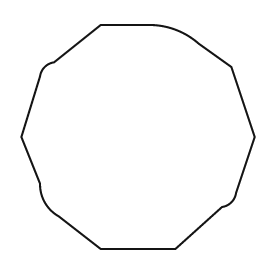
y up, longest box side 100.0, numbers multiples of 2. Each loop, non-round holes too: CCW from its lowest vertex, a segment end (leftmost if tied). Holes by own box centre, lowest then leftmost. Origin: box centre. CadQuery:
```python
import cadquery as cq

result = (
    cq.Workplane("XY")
    .moveTo(-16.0, -48.0)
    .lineTo(16.0, -48.0)
    .lineTo(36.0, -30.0)
    .threePointArc((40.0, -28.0), (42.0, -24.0))
    .lineTo(50.0, 0.0)
    .lineTo(40.0, 30.0)
    .lineTo(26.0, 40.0)
    .threePointArc((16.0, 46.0), (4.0, 48.0))
    .lineTo(-16.0, 48.0)
    .lineTo(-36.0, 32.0)
    .threePointArc((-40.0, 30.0), (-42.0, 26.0))
    .lineTo(-50.0, 0.0)
    .lineTo(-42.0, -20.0)
    .threePointArc((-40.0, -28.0), (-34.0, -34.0))
    .close()
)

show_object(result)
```